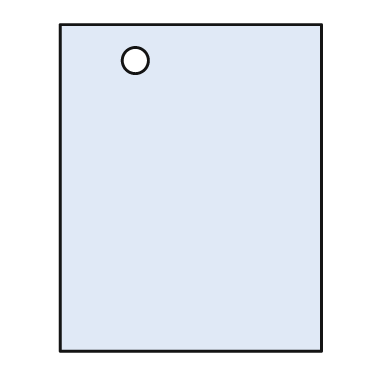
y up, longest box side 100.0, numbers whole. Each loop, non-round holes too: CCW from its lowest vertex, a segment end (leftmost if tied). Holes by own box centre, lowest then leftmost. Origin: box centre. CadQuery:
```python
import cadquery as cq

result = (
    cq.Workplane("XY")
    .moveTo(-40.0, -50.0)
    .lineTo(40.0, -50.0)
    .lineTo(40.0, 50.0)
    .lineTo(-40.0, 50.0)
    .close()
    .moveTo(-17.0, 39.0)
    .circle(4.0)
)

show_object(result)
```